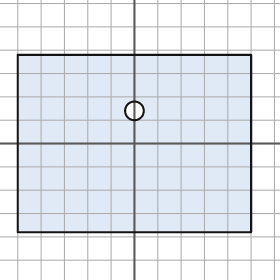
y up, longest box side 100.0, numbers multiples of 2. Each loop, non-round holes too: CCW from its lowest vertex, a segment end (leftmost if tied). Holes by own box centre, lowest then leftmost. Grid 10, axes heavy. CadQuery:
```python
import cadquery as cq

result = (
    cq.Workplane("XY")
    .moveTo(-50.0, -38.0)
    .lineTo(50.0, -38.0)
    .lineTo(50.0, 38.0)
    .lineTo(-50.0, 38.0)
    .close()
    .moveTo(0.0, 14.0)
    .circle(4.0)
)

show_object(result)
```